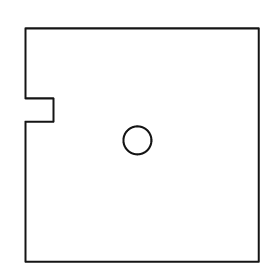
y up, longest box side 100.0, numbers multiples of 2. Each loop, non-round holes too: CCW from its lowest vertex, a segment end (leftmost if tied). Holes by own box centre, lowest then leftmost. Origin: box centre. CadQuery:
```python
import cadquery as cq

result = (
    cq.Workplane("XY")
    .moveTo(-50.0, -50.0)
    .lineTo(50.0, -50.0)
    .lineTo(50.0, 50.0)
    .lineTo(-50.0, 50.0)
    .lineTo(-50.0, 20.0)
    .lineTo(-38.0, 20.0)
    .lineTo(-38.0, 10.0)
    .lineTo(-50.0, 10.0)
    .close()
    .moveTo(-2.0, 2.0)
    .circle(6.0)
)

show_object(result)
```